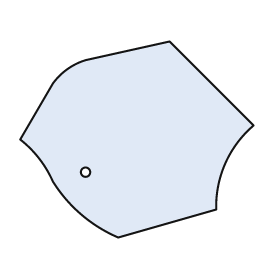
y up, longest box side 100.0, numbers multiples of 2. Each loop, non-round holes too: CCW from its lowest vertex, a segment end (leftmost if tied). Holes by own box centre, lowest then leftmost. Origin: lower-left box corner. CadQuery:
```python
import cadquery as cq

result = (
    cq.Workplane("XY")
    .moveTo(42.0, 0.0)
    .lineTo(84.0, 12.0)
    .threePointArc((88.0, 32.0), (100.0, 48.0))
    .lineTo(64.0, 84.0)
    .lineTo(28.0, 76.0)
    .threePointArc((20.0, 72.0), (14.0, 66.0))
    .lineTo(0.0, 42.0)
    .threePointArc((8.0, 34.0), (14.0, 24.0))
    .threePointArc((26.0, 10.0), (42.0, 0.0))
    .close()
    .moveTo(28.0, 28.0)
    .circle(2.0)
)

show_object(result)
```